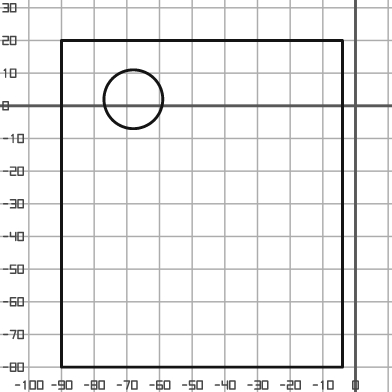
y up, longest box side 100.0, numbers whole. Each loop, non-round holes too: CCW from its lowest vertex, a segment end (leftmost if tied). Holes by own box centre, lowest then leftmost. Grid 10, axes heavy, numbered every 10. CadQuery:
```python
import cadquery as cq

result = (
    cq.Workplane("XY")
    .moveTo(-90.0, -80.0)
    .lineTo(-4.0, -80.0)
    .lineTo(-4.0, 20.0)
    .lineTo(-90.0, 20.0)
    .close()
    .moveTo(-68.0, 2.0)
    .circle(9.0)
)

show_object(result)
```